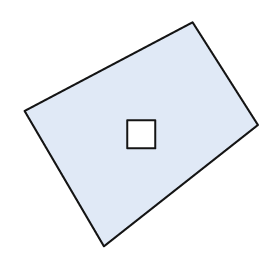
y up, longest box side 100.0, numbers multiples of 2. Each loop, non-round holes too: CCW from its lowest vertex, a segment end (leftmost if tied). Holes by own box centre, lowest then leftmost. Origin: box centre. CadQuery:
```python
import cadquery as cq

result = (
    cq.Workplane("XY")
    .moveTo(-16.0, -48.0)
    .lineTo(50.0, 4.0)
    .lineTo(22.0, 48.0)
    .lineTo(-50.0, 10.0)
    .close()
    .moveTo(-6.0, -6.0)
    .lineTo(6.0, -6.0)
    .lineTo(6.0, 6.0)
    .lineTo(-6.0, 6.0)
    .close()
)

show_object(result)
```